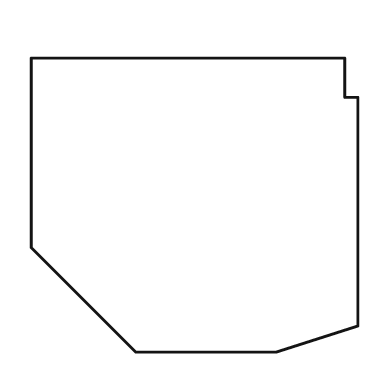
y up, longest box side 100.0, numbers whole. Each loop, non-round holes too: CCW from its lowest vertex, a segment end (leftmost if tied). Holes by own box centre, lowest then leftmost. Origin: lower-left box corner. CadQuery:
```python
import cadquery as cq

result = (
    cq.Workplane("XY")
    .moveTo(32.0, 0.0)
    .lineTo(75.0, 0.0)
    .lineTo(100.0, 8.0)
    .lineTo(100.0, 78.0)
    .lineTo(96.0, 78.0)
    .lineTo(96.0, 90.0)
    .lineTo(0.0, 90.0)
    .lineTo(0.0, 32.0)
    .close()
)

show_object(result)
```